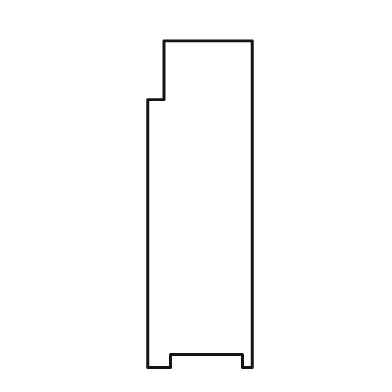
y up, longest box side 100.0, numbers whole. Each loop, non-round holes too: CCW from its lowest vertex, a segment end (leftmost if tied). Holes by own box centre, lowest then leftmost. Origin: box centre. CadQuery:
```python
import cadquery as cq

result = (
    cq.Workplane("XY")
    .moveTo(-16.0, -50.0)
    .lineTo(-9.0, -50.0)
    .lineTo(-9.0, -46.0)
    .lineTo(13.0, -46.0)
    .lineTo(13.0, -50.0)
    .lineTo(16.0, -50.0)
    .lineTo(16.0, 50.0)
    .lineTo(-11.0, 50.0)
    .lineTo(-11.0, 32.0)
    .lineTo(-16.0, 32.0)
    .close()
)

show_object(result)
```